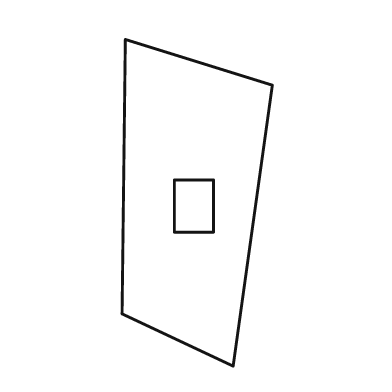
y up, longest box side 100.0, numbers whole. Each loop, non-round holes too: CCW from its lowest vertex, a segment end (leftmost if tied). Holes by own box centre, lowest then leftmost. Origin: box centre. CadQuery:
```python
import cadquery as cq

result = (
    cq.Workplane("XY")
    .moveTo(11.0, -50.0)
    .lineTo(23.0, 36.0)
    .lineTo(-22.0, 50.0)
    .lineTo(-23.0, -34.0)
    .close()
    .moveTo(-7.0, -9.0)
    .lineTo(5.0, -9.0)
    .lineTo(5.0, 7.0)
    .lineTo(-7.0, 7.0)
    .close()
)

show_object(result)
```